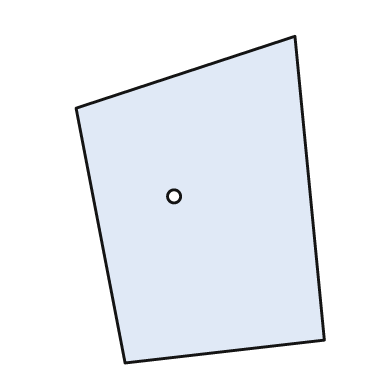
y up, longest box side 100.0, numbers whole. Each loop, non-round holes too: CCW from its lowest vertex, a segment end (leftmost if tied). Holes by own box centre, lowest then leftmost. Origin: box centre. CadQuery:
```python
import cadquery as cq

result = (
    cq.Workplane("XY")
    .moveTo(-23.0, -50.0)
    .lineTo(38.0, -43.0)
    .lineTo(29.0, 50.0)
    .lineTo(-38.0, 28.0)
    .close()
    .moveTo(-8.0, 1.0)
    .circle(2.0)
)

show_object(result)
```